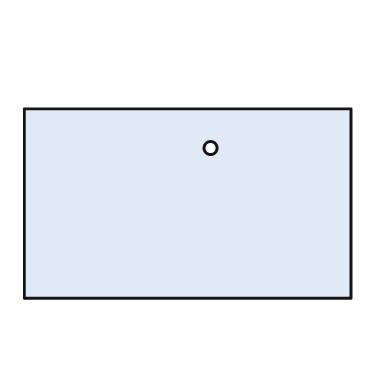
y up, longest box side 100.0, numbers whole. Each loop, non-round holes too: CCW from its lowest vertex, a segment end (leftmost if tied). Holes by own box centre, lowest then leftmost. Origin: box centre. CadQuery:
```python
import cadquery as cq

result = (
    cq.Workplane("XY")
    .moveTo(-50.0, -29.0)
    .lineTo(50.0, -29.0)
    .lineTo(50.0, 29.0)
    .lineTo(-50.0, 29.0)
    .close()
    .moveTo(7.0, 17.0)
    .circle(2.0)
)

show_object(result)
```